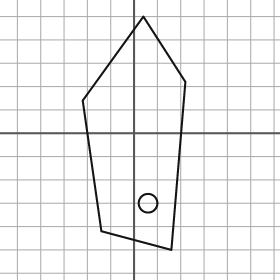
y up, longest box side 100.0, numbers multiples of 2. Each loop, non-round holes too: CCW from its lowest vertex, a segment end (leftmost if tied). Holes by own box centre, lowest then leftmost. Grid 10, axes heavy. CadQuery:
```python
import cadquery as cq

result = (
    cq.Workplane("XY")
    .moveTo(16.0, -50.0)
    .lineTo(22.0, 22.0)
    .lineTo(4.0, 50.0)
    .lineTo(-22.0, 14.0)
    .lineTo(-14.0, -42.0)
    .close()
    .moveTo(6.0, -30.0)
    .circle(4.0)
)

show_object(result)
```